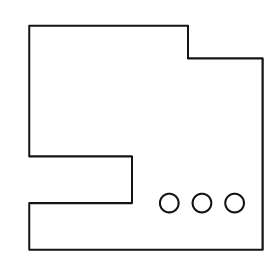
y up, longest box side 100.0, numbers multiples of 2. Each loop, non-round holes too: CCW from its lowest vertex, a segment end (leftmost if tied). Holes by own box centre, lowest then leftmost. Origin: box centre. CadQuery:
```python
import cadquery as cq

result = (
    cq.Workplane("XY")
    .moveTo(-50.0, -48.0)
    .lineTo(50.0, -48.0)
    .lineTo(50.0, 34.0)
    .lineTo(18.0, 34.0)
    .lineTo(18.0, 48.0)
    .lineTo(-50.0, 48.0)
    .lineTo(-50.0, -8.0)
    .lineTo(-6.0, -8.0)
    .lineTo(-6.0, -28.0)
    .lineTo(-50.0, -28.0)
    .close()
    .moveTo(10.0, -28.0)
    .circle(4.0)
    .moveTo(24.0, -28.0)
    .circle(4.0)
    .moveTo(38.0, -28.0)
    .circle(4.0)
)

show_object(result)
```